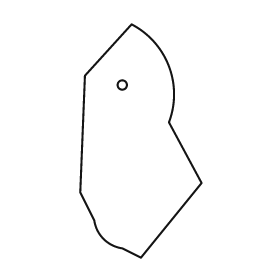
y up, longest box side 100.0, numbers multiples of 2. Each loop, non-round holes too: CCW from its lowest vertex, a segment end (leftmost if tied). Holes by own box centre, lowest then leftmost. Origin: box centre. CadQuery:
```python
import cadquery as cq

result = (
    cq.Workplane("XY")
    .moveTo(0.0, -50.0)
    .lineTo(26.0, -18.0)
    .lineTo(12.0, 8.0)
    .threePointArc((12.0, 32.0), (-4.0, 50.0))
    .lineTo(-24.0, 28.0)
    .lineTo(-26.0, -22.0)
    .lineTo(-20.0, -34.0)
    .threePointArc((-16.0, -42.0), (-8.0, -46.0))
    .close()
    .moveTo(-8.0, 24.0)
    .circle(2.0)
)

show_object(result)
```